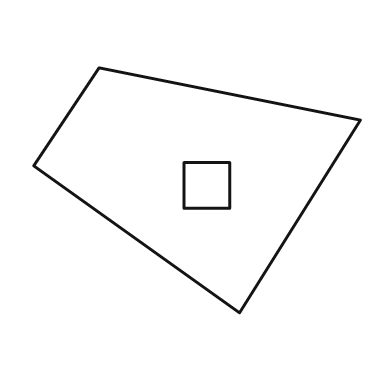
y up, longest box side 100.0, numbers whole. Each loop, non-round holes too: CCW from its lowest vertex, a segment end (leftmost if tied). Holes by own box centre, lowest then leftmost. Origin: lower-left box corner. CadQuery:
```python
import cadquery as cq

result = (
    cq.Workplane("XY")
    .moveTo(63.0, 0.0)
    .lineTo(100.0, 59.0)
    .lineTo(20.0, 75.0)
    .lineTo(0.0, 45.0)
    .close()
    .moveTo(46.0, 32.0)
    .lineTo(60.0, 32.0)
    .lineTo(60.0, 46.0)
    .lineTo(46.0, 46.0)
    .close()
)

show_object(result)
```